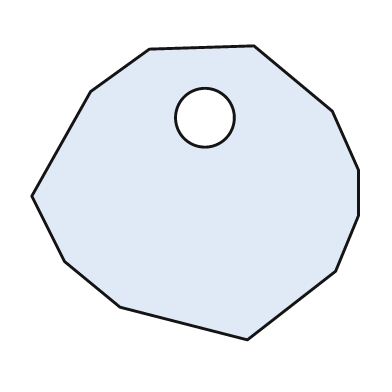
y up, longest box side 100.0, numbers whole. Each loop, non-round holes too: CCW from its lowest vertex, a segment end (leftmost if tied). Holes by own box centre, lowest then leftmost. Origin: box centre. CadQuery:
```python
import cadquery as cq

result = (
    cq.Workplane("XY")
    .moveTo(16.0, -45.0)
    .lineTo(43.0, -24.0)
    .lineTo(50.0, -7.0)
    .lineTo(50.0, 7.0)
    .lineTo(42.0, 25.0)
    .lineTo(18.0, 45.0)
    .lineTo(-14.0, 44.0)
    .lineTo(-32.0, 31.0)
    .lineTo(-50.0, -1.0)
    .lineTo(-40.0, -21.0)
    .lineTo(-23.0, -35.0)
    .close()
    .moveTo(3.0, 23.0)
    .circle(9.0)
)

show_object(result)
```